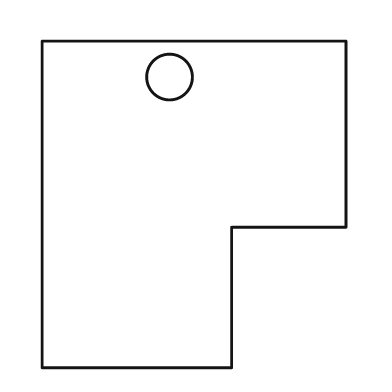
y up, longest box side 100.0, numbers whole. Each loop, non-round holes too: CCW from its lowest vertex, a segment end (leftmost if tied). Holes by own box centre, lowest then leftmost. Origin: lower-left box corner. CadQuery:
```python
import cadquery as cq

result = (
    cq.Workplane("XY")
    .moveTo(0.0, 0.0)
    .lineTo(58.0, 0.0)
    .lineTo(58.0, 43.0)
    .lineTo(93.0, 43.0)
    .lineTo(93.0, 100.0)
    .lineTo(0.0, 100.0)
    .close()
    .moveTo(39.0, 89.0)
    .circle(7.0)
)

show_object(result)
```